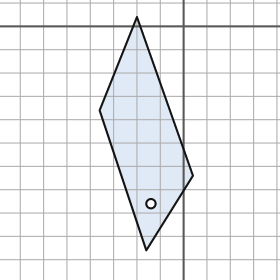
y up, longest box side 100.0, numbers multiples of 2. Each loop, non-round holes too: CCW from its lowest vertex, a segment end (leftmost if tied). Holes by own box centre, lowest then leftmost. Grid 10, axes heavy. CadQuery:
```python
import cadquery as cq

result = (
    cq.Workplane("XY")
    .moveTo(-16.0, -96.0)
    .lineTo(4.0, -64.0)
    .lineTo(-20.0, 4.0)
    .lineTo(-36.0, -36.0)
    .close()
    .moveTo(-14.0, -76.0)
    .circle(2.0)
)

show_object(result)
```